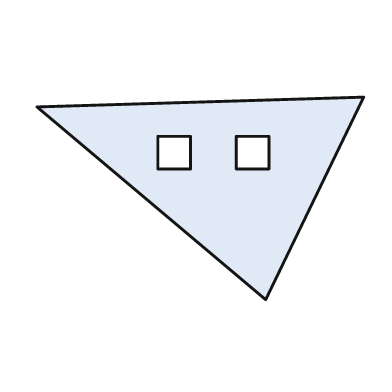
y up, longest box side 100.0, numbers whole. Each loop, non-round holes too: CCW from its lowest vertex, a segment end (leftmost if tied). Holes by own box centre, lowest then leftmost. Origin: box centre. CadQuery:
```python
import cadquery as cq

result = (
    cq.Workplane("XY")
    .moveTo(20.0, -31.0)
    .lineTo(50.0, 31.0)
    .lineTo(-50.0, 28.0)
    .close()
    .moveTo(-13.0, 9.0)
    .lineTo(-3.0, 9.0)
    .lineTo(-3.0, 19.0)
    .lineTo(-13.0, 19.0)
    .close()
    .moveTo(11.0, 9.0)
    .lineTo(21.0, 9.0)
    .lineTo(21.0, 19.0)
    .lineTo(11.0, 19.0)
    .close()
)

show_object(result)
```